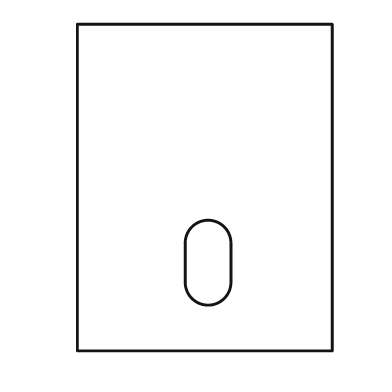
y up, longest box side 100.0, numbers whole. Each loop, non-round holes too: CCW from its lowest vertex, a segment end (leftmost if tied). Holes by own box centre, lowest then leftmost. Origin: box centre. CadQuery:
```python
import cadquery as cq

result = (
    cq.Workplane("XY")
    .moveTo(-39.0, -50.0)
    .lineTo(39.0, -50.0)
    .lineTo(39.0, 50.0)
    .lineTo(-39.0, 50.0)
    .close()
    .moveTo(-6.0, -29.0)
    .threePointArc((1.0, -36.0), (8.0, -29.0))
    .lineTo(8.0, -17.0)
    .threePointArc((1.0, -10.0), (-6.0, -17.0))
    .close()
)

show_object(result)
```